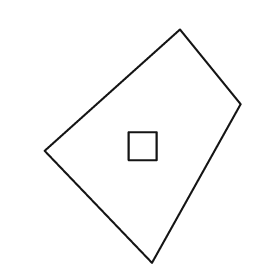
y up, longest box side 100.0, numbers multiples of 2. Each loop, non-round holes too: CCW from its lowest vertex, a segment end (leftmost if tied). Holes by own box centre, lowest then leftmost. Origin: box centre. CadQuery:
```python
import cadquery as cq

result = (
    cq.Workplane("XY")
    .moveTo(4.0, -50.0)
    .lineTo(42.0, 18.0)
    .lineTo(16.0, 50.0)
    .lineTo(-42.0, -2.0)
    .close()
    .moveTo(-6.0, -6.0)
    .lineTo(6.0, -6.0)
    .lineTo(6.0, 6.0)
    .lineTo(-6.0, 6.0)
    .close()
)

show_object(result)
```